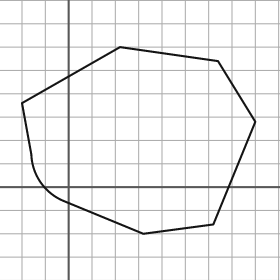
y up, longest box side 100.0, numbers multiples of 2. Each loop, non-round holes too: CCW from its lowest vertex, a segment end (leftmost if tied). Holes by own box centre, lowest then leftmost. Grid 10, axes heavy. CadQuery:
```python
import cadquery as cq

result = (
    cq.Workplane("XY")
    .moveTo(32.0, -20.0)
    .lineTo(62.0, -16.0)
    .lineTo(80.0, 28.0)
    .lineTo(64.0, 54.0)
    .lineTo(22.0, 60.0)
    .lineTo(-20.0, 36.0)
    .lineTo(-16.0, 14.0)
    .threePointArc((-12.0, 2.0), (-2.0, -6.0))
    .close()
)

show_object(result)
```